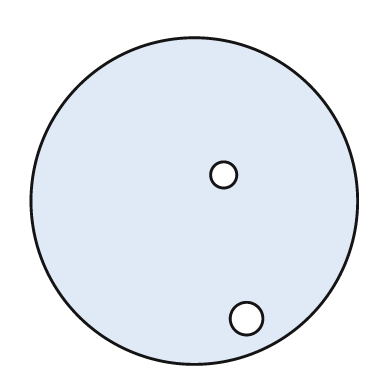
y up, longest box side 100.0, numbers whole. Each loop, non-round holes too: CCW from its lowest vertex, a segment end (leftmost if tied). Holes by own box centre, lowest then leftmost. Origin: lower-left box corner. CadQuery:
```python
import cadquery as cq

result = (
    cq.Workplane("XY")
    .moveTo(50.0, 50.0)
    .circle(50.0)
    .moveTo(66.0, 14.0)
    .circle(5.0)
    .moveTo(59.0, 58.0)
    .circle(4.0)
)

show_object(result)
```